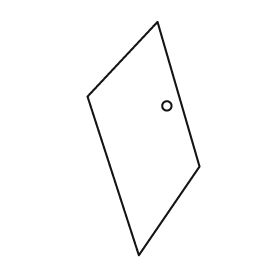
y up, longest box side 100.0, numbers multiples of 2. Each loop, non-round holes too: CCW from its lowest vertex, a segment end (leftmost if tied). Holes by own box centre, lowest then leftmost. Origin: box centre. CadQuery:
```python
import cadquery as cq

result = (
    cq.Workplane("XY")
    .moveTo(-2.0, -50.0)
    .lineTo(24.0, -12.0)
    .lineTo(6.0, 50.0)
    .lineTo(-24.0, 18.0)
    .close()
    .moveTo(10.0, 14.0)
    .circle(2.0)
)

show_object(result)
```